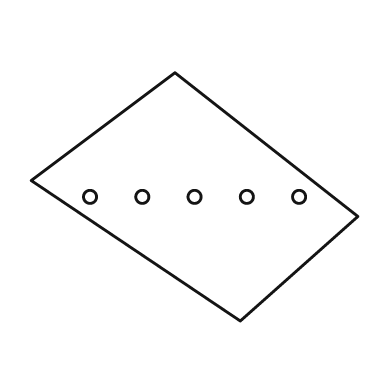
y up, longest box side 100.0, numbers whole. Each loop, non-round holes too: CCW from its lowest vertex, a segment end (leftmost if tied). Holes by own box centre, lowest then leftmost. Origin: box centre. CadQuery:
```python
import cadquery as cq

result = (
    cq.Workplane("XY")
    .moveTo(14.0, -38.0)
    .lineTo(50.0, -6.0)
    .lineTo(-6.0, 38.0)
    .lineTo(-50.0, 5.0)
    .close()
    .moveTo(-32.0, 0.0)
    .circle(2.0)
    .moveTo(-16.0, 0.0)
    .circle(2.0)
    .moveTo(0.0, 0.0)
    .circle(2.0)
    .moveTo(16.0, 0.0)
    .circle(2.0)
    .moveTo(32.0, 0.0)
    .circle(2.0)
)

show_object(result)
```